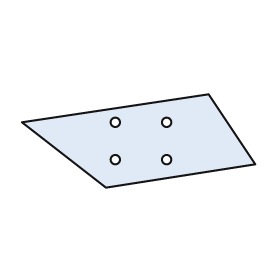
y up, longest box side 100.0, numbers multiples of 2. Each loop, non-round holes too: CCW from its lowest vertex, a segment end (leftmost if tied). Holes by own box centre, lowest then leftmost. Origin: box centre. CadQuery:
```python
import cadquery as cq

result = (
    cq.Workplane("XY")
    .moveTo(-14.0, -20.0)
    .lineTo(50.0, -10.0)
    .lineTo(30.0, 20.0)
    .lineTo(-50.0, 8.0)
    .close()
    .moveTo(-10.0, -8.0)
    .circle(2.0)
    .moveTo(12.0, -8.0)
    .circle(2.0)
    .moveTo(-10.0, 8.0)
    .circle(2.0)
    .moveTo(12.0, 8.0)
    .circle(2.0)
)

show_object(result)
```